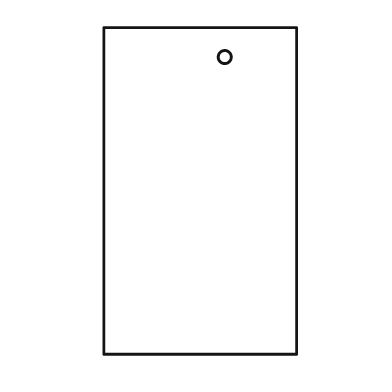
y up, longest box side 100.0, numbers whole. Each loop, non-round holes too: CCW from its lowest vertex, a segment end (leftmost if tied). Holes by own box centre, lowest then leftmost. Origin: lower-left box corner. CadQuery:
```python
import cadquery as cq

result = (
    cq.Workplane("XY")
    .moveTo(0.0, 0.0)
    .lineTo(59.0, 0.0)
    .lineTo(59.0, 100.0)
    .lineTo(0.0, 100.0)
    .close()
    .moveTo(37.0, 91.0)
    .circle(2.0)
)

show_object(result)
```